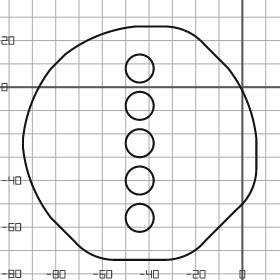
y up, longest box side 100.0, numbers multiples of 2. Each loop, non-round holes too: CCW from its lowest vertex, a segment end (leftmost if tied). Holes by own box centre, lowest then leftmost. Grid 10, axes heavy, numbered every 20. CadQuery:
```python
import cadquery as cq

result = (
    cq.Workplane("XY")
    .moveTo(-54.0, -74.0)
    .lineTo(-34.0, -74.0)
    .threePointArc((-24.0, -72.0), (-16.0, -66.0))
    .lineTo(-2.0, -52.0)
    .threePointArc((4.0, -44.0), (6.0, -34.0))
    .lineTo(6.0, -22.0)
    .threePointArc((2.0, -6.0), (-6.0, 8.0))
    .lineTo(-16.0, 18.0)
    .threePointArc((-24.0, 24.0), (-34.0, 26.0))
    .lineTo(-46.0, 26.0)
    .threePointArc((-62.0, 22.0), (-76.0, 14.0))
    .lineTo(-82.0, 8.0)
    .threePointArc((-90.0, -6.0), (-94.0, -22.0))
    .lineTo(-94.0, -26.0)
    .threePointArc((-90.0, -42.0), (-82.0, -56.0))
    .lineTo(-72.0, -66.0)
    .threePointArc((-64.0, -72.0), (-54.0, -74.0))
    .close()
    .moveTo(-44.0, -56.0)
    .circle(6.0)
    .moveTo(-44.0, -40.0)
    .circle(6.0)
    .moveTo(-44.0, -24.0)
    .circle(6.0)
    .moveTo(-44.0, -8.0)
    .circle(6.0)
    .moveTo(-44.0, 8.0)
    .circle(6.0)
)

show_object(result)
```